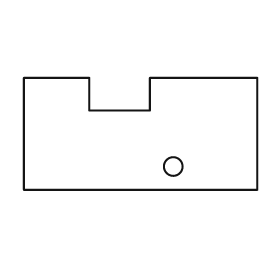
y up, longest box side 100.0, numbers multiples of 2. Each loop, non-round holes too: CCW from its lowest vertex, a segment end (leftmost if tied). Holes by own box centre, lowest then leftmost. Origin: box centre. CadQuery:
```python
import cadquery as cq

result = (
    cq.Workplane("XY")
    .moveTo(-50.0, -24.0)
    .lineTo(50.0, -24.0)
    .lineTo(50.0, 24.0)
    .lineTo(4.0, 24.0)
    .lineTo(4.0, 10.0)
    .lineTo(-22.0, 10.0)
    .lineTo(-22.0, 24.0)
    .lineTo(-50.0, 24.0)
    .close()
    .moveTo(14.0, -14.0)
    .circle(4.0)
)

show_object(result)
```